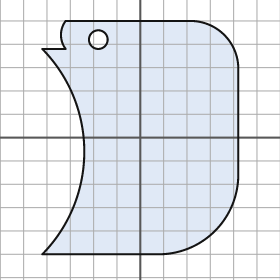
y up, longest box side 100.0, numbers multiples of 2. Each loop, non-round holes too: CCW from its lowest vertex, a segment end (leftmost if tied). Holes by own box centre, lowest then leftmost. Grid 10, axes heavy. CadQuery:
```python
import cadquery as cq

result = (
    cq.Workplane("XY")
    .moveTo(-42.0, -50.0)
    .lineTo(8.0, -50.0)
    .threePointArc((32.0, -40.0), (42.0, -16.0))
    .lineTo(42.0, 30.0)
    .threePointArc((36.0, 44.0), (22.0, 50.0))
    .lineTo(-32.0, 50.0)
    .threePointArc((-34.0, 44.0), (-32.0, 38.0))
    .lineTo(-42.0, 38.0)
    .threePointArc((-24.0, -6.0), (-42.0, -50.0))
    .close()
    .moveTo(-18.0, 42.0)
    .circle(4.0)
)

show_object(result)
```